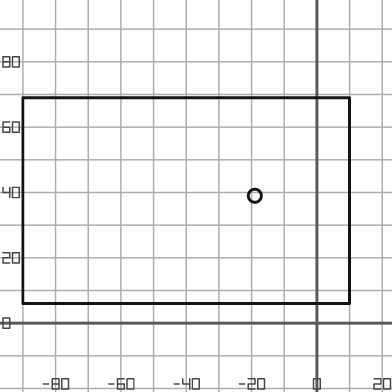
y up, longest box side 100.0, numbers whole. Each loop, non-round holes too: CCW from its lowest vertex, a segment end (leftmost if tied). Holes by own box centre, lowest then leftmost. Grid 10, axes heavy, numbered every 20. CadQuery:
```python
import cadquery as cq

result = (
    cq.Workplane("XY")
    .moveTo(-90.0, 6.0)
    .lineTo(10.0, 6.0)
    .lineTo(10.0, 69.0)
    .lineTo(-90.0, 69.0)
    .close()
    .moveTo(-19.0, 39.0)
    .circle(2.0)
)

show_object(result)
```